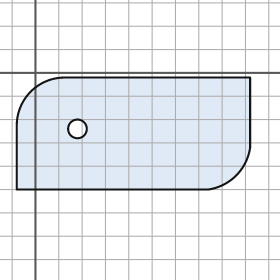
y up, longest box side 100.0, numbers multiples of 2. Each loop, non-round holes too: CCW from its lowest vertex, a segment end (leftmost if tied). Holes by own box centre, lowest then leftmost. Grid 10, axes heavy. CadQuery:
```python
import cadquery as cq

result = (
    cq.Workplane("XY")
    .moveTo(-8.0, -50.0)
    .lineTo(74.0, -50.0)
    .threePointArc((86.0, -44.0), (92.0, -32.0))
    .lineTo(92.0, -2.0)
    .lineTo(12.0, -2.0)
    .threePointArc((-2.0, -8.0), (-8.0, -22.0))
    .close()
    .moveTo(18.0, -24.0)
    .circle(4.0)
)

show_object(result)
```